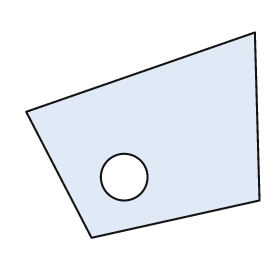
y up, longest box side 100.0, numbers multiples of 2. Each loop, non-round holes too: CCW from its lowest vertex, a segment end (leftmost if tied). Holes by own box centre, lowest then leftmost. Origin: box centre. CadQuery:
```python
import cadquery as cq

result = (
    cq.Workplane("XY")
    .moveTo(-22.0, -44.0)
    .lineTo(50.0, -28.0)
    .lineTo(48.0, 44.0)
    .lineTo(-50.0, 10.0)
    .close()
    .moveTo(-8.0, -18.0)
    .circle(10.0)
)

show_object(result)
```